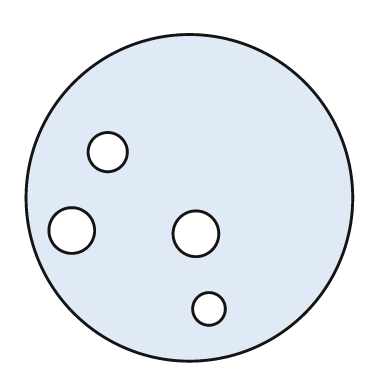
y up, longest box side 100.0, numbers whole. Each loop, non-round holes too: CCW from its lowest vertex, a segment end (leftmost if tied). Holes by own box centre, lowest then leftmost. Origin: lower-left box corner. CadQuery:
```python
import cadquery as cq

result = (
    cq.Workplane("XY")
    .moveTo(50.0, 50.0)
    .circle(50.0)
    .moveTo(56.0, 16.0)
    .circle(5.0)
    .moveTo(52.0, 39.0)
    .circle(7.0)
    .moveTo(14.0, 40.0)
    .circle(7.0)
    .moveTo(25.0, 64.0)
    .circle(6.0)
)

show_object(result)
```